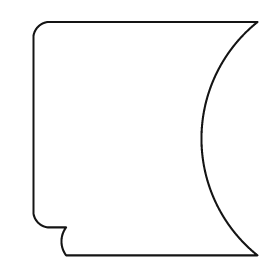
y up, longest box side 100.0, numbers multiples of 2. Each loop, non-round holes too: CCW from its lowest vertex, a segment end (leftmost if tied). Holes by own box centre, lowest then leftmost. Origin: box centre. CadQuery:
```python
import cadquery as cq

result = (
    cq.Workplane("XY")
    .moveTo(-34.0, -50.0)
    .lineTo(48.0, -50.0)
    .threePointArc((24.0, 0.0), (48.0, 50.0))
    .lineTo(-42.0, 50.0)
    .threePointArc((-46.0, 48.0), (-48.0, 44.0))
    .lineTo(-48.0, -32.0)
    .threePointArc((-46.0, -36.0), (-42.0, -38.0))
    .lineTo(-34.0, -38.0)
    .threePointArc((-36.0, -44.0), (-34.0, -50.0))
    .close()
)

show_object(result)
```